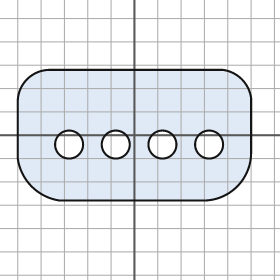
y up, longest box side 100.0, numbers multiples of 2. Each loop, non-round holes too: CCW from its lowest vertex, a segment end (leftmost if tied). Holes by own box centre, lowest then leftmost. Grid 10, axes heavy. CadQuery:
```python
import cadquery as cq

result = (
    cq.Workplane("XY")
    .moveTo(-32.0, -28.0)
    .lineTo(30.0, -28.0)
    .threePointArc((44.0, -22.0), (50.0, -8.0))
    .lineTo(50.0, 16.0)
    .threePointArc((46.0, 24.0), (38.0, 28.0))
    .lineTo(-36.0, 28.0)
    .threePointArc((-46.0, 24.0), (-50.0, 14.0))
    .lineTo(-50.0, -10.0)
    .threePointArc((-44.0, -22.0), (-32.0, -28.0))
    .close()
    .moveTo(-28.0, -4.0)
    .circle(6.0)
    .moveTo(-8.0, -4.0)
    .circle(6.0)
    .moveTo(12.0, -4.0)
    .circle(6.0)
    .moveTo(32.0, -4.0)
    .circle(6.0)
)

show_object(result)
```